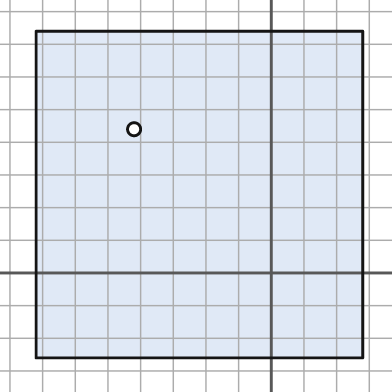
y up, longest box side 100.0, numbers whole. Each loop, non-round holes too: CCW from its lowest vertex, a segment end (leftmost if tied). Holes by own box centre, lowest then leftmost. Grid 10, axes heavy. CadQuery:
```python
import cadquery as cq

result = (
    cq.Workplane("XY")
    .moveTo(-72.0, -26.0)
    .lineTo(28.0, -26.0)
    .lineTo(28.0, 74.0)
    .lineTo(-72.0, 74.0)
    .close()
    .moveTo(-42.0, 44.0)
    .circle(2.0)
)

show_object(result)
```